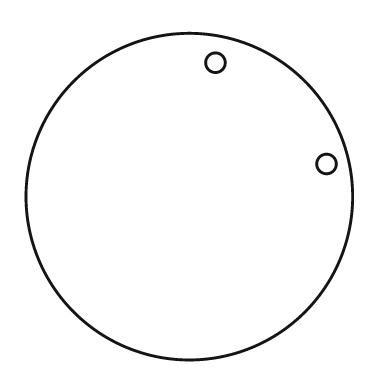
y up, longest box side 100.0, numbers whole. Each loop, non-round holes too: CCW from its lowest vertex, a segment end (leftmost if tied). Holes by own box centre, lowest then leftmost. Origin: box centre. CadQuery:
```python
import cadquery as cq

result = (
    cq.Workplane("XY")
    .moveTo(0.0, 0.0)
    .circle(50.0)
    .moveTo(42.0, 10.0)
    .circle(3.0)
    .moveTo(8.0, 41.0)
    .circle(3.0)
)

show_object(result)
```